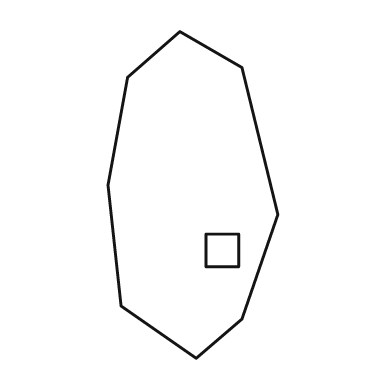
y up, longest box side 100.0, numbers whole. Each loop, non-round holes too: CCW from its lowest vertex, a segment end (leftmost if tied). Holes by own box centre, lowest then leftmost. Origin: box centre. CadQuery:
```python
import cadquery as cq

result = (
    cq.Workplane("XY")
    .moveTo(1.0, -50.0)
    .lineTo(15.0, -38.0)
    .lineTo(26.0, -6.0)
    .lineTo(15.0, 39.0)
    .lineTo(-4.0, 50.0)
    .lineTo(-20.0, 36.0)
    .lineTo(-26.0, 3.0)
    .lineTo(-22.0, -34.0)
    .close()
    .moveTo(4.0, -22.0)
    .lineTo(14.0, -22.0)
    .lineTo(14.0, -12.0)
    .lineTo(4.0, -12.0)
    .close()
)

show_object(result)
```